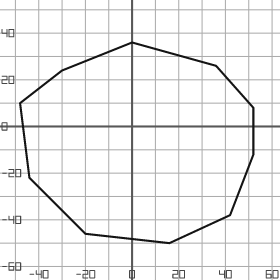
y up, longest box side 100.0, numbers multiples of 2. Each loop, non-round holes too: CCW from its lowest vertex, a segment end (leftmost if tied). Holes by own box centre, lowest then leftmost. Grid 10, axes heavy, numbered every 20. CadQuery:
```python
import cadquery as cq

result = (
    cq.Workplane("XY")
    .moveTo(16.0, -50.0)
    .lineTo(42.0, -38.0)
    .lineTo(52.0, -12.0)
    .lineTo(52.0, 8.0)
    .lineTo(36.0, 26.0)
    .lineTo(0.0, 36.0)
    .lineTo(-30.0, 24.0)
    .lineTo(-48.0, 10.0)
    .lineTo(-44.0, -22.0)
    .lineTo(-20.0, -46.0)
    .close()
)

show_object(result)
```